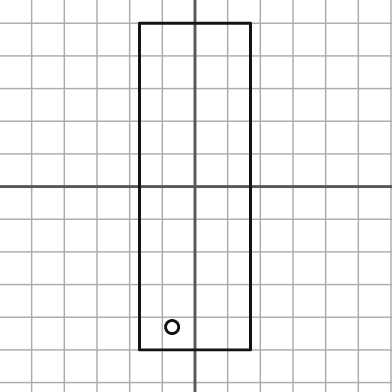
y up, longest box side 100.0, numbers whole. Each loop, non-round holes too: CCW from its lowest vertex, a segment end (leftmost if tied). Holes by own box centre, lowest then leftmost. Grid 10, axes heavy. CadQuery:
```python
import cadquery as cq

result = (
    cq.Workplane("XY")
    .moveTo(-17.0, -50.0)
    .lineTo(17.0, -50.0)
    .lineTo(17.0, 50.0)
    .lineTo(-17.0, 50.0)
    .close()
    .moveTo(-7.0, -43.0)
    .circle(2.0)
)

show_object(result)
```